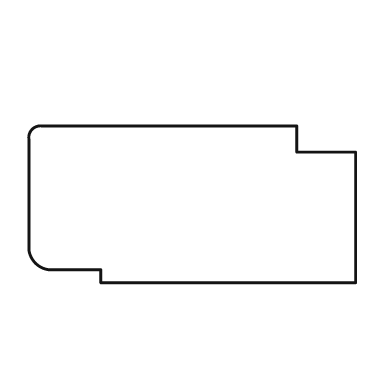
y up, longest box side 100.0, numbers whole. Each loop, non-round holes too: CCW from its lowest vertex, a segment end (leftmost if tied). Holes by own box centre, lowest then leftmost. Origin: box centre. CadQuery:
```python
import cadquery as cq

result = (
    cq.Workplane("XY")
    .moveTo(-28.0, -24.0)
    .lineTo(50.0, -24.0)
    .lineTo(50.0, 16.0)
    .lineTo(32.0, 16.0)
    .lineTo(32.0, 24.0)
    .lineTo(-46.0, 24.0)
    .threePointArc((-49.0, 23.0), (-50.0, 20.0))
    .lineTo(-50.0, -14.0)
    .threePointArc((-48.0, -18.0), (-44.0, -20.0))
    .lineTo(-28.0, -20.0)
    .close()
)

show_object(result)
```